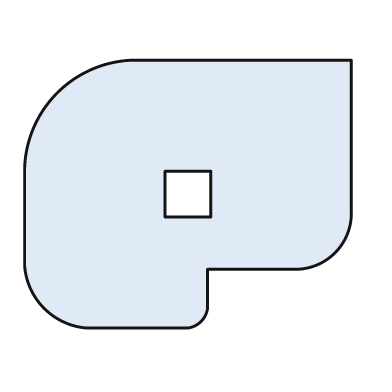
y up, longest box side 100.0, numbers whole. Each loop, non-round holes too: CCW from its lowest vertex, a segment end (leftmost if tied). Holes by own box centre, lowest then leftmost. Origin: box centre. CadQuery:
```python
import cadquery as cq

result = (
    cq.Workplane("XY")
    .moveTo(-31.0, -41.0)
    .lineTo(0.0, -41.0)
    .threePointArc((4.0, -39.0), (6.0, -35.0))
    .lineTo(6.0, -23.0)
    .lineTo(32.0, -23.0)
    .threePointArc((45.0, -18.0), (50.0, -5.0))
    .lineTo(50.0, 41.0)
    .lineTo(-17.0, 41.0)
    .threePointArc((-40.0, 31.0), (-50.0, 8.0))
    .lineTo(-50.0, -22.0)
    .threePointArc((-44.0, -35.0), (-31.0, -41.0))
    .close()
    .moveTo(-7.0, -7.0)
    .lineTo(7.0, -7.0)
    .lineTo(7.0, 7.0)
    .lineTo(-7.0, 7.0)
    .close()
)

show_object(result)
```